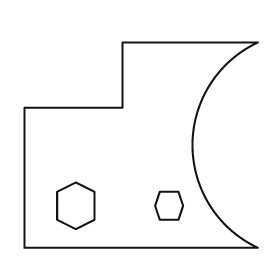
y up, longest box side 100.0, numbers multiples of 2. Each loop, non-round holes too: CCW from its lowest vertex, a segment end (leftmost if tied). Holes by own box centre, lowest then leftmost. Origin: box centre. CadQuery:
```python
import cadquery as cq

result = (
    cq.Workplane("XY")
    .moveTo(-50.0, -44.0)
    .lineTo(50.0, -44.0)
    .threePointArc((22.0, 0.0), (50.0, 44.0))
    .lineTo(-8.0, 44.0)
    .lineTo(-8.0, 16.0)
    .lineTo(-50.0, 16.0)
    .close()
    .moveTo(-28.0, -36.0)
    .lineTo(-20.0, -32.0)
    .lineTo(-20.0, -20.0)
    .lineTo(-28.0, -16.0)
    .lineTo(-36.0, -20.0)
    .lineTo(-36.0, -32.0)
    .close()
    .moveTo(8.0, -32.0)
    .lineTo(16.0, -32.0)
    .lineTo(18.0, -26.0)
    .lineTo(16.0, -20.0)
    .lineTo(8.0, -20.0)
    .lineTo(6.0, -26.0)
    .close()
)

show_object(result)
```